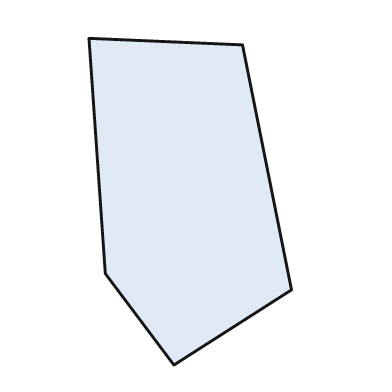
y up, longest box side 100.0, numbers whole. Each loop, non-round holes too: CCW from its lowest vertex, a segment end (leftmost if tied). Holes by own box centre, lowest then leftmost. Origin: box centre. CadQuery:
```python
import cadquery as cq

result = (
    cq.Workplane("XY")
    .moveTo(-5.0, -50.0)
    .lineTo(31.0, -27.0)
    .lineTo(16.0, 48.0)
    .lineTo(-31.0, 50.0)
    .lineTo(-26.0, -22.0)
    .close()
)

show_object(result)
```